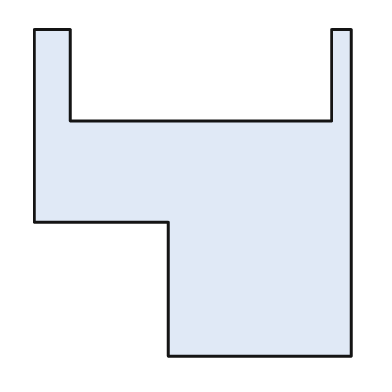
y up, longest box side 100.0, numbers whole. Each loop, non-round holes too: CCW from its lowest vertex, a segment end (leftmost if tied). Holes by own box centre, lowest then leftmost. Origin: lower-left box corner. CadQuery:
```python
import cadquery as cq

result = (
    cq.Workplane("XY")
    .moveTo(41.0, 0.0)
    .lineTo(97.0, 0.0)
    .lineTo(97.0, 100.0)
    .lineTo(91.0, 100.0)
    .lineTo(91.0, 72.0)
    .lineTo(11.0, 72.0)
    .lineTo(11.0, 100.0)
    .lineTo(0.0, 100.0)
    .lineTo(0.0, 41.0)
    .lineTo(41.0, 41.0)
    .close()
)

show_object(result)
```